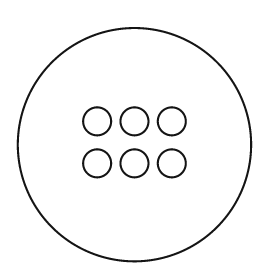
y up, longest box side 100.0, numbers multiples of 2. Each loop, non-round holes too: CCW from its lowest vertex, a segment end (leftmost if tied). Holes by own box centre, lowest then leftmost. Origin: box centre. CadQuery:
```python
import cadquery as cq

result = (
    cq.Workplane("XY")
    .moveTo(0.0, 0.0)
    .circle(50.0)
    .moveTo(-16.0, -8.0)
    .circle(6.0)
    .moveTo(0.0, -8.0)
    .circle(6.0)
    .moveTo(16.0, -8.0)
    .circle(6.0)
    .moveTo(-16.0, 10.0)
    .circle(6.0)
    .moveTo(0.0, 10.0)
    .circle(6.0)
    .moveTo(16.0, 10.0)
    .circle(6.0)
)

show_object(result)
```